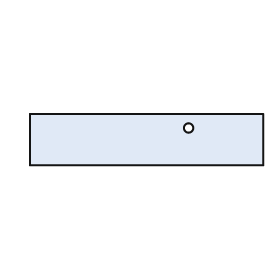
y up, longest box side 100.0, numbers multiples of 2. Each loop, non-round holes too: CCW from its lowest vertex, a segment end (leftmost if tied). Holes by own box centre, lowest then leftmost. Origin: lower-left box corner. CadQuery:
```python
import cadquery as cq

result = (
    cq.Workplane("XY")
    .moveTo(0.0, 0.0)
    .lineTo(100.0, 0.0)
    .lineTo(100.0, 22.0)
    .lineTo(0.0, 22.0)
    .close()
    .moveTo(68.0, 16.0)
    .circle(2.0)
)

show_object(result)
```